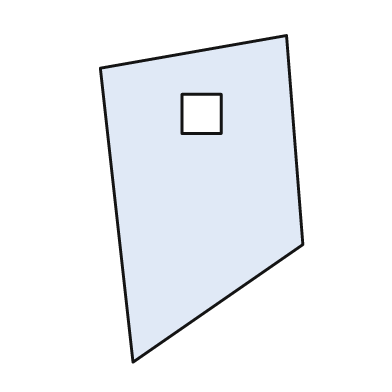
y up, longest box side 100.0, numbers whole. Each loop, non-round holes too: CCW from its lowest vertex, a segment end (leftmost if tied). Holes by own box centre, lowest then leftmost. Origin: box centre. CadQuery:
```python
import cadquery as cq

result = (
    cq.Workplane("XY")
    .moveTo(-21.0, -50.0)
    .lineTo(31.0, -14.0)
    .lineTo(26.0, 50.0)
    .lineTo(-31.0, 40.0)
    .close()
    .moveTo(-6.0, 20.0)
    .lineTo(6.0, 20.0)
    .lineTo(6.0, 32.0)
    .lineTo(-6.0, 32.0)
    .close()
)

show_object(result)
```